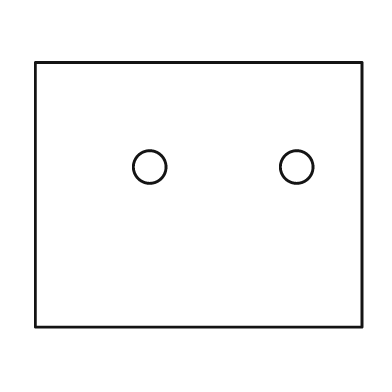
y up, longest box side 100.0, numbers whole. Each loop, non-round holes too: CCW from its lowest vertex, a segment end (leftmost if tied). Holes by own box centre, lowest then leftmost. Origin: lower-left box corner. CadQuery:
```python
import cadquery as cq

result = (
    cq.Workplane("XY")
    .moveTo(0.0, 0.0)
    .lineTo(100.0, 0.0)
    .lineTo(100.0, 81.0)
    .lineTo(0.0, 81.0)
    .close()
    .moveTo(35.0, 49.0)
    .circle(5.0)
    .moveTo(80.0, 49.0)
    .circle(5.0)
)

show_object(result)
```